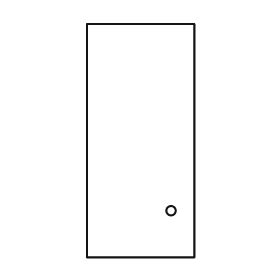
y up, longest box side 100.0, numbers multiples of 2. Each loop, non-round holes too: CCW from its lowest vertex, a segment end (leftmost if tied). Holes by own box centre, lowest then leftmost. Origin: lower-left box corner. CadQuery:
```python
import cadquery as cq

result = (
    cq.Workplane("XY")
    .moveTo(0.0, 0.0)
    .lineTo(46.0, 0.0)
    .lineTo(46.0, 100.0)
    .lineTo(0.0, 100.0)
    .close()
    .moveTo(36.0, 20.0)
    .circle(2.0)
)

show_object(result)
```